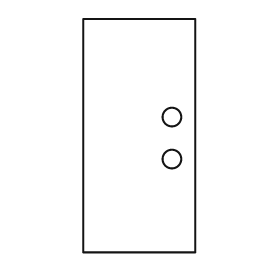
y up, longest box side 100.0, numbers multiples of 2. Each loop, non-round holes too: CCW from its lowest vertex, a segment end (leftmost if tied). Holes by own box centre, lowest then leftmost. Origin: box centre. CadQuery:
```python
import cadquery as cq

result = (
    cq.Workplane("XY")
    .moveTo(-24.0, -50.0)
    .lineTo(24.0, -50.0)
    .lineTo(24.0, 50.0)
    .lineTo(-24.0, 50.0)
    .close()
    .moveTo(14.0, -10.0)
    .circle(4.0)
    .moveTo(14.0, 8.0)
    .circle(4.0)
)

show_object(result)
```